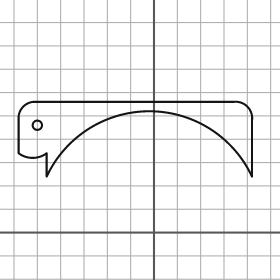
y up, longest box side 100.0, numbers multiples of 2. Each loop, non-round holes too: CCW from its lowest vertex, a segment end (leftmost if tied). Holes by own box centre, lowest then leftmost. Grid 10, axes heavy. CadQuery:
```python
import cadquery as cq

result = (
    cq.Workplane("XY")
    .moveTo(-46.0, 24.0)
    .threePointArc((-2.0, 52.0), (42.0, 24.0))
    .lineTo(42.0, 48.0)
    .threePointArc((40.0, 54.0), (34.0, 56.0))
    .lineTo(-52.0, 56.0)
    .threePointArc((-56.0, 54.0), (-58.0, 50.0))
    .lineTo(-58.0, 34.0)
    .threePointArc((-52.0, 32.0), (-46.0, 34.0))
    .close()
    .moveTo(-50.0, 46.0)
    .circle(2.0)
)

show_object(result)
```